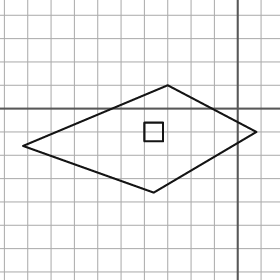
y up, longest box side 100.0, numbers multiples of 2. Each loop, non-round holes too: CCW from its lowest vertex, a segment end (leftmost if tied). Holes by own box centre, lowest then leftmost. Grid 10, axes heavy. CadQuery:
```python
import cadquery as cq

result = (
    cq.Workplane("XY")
    .moveTo(-36.0, -36.0)
    .lineTo(8.0, -10.0)
    .lineTo(-30.0, 10.0)
    .lineTo(-92.0, -16.0)
    .close()
    .moveTo(-40.0, -14.0)
    .lineTo(-32.0, -14.0)
    .lineTo(-32.0, -6.0)
    .lineTo(-40.0, -6.0)
    .close()
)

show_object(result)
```